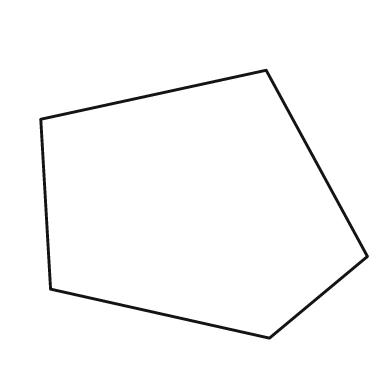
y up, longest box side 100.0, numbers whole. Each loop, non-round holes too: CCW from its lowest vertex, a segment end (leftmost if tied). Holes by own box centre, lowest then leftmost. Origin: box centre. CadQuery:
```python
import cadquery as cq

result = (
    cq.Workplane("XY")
    .moveTo(20.0, -41.0)
    .lineTo(50.0, -16.0)
    .lineTo(19.0, 41.0)
    .lineTo(-50.0, 26.0)
    .lineTo(-47.0, -26.0)
    .close()
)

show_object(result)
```